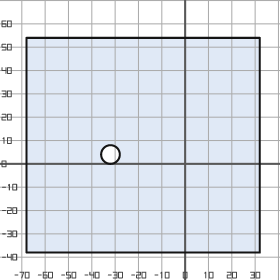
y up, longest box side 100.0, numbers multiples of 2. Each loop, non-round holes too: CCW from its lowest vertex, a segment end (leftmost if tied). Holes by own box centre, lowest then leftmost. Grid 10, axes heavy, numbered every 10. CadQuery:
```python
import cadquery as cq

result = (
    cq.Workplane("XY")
    .moveTo(-68.0, -38.0)
    .lineTo(32.0, -38.0)
    .lineTo(32.0, 54.0)
    .lineTo(-68.0, 54.0)
    .close()
    .moveTo(-32.0, 4.0)
    .circle(4.0)
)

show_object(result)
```